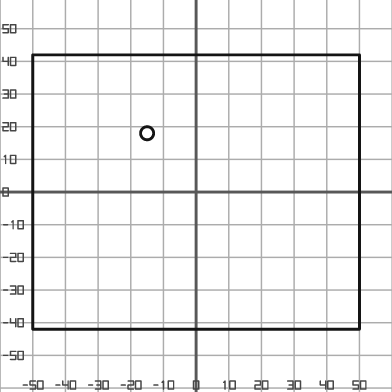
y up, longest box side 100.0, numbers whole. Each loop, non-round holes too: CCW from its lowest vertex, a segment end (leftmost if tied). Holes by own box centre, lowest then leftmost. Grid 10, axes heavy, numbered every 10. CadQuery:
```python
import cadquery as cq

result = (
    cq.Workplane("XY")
    .moveTo(-50.0, -42.0)
    .lineTo(50.0, -42.0)
    .lineTo(50.0, 42.0)
    .lineTo(-50.0, 42.0)
    .close()
    .moveTo(-15.0, 18.0)
    .circle(2.0)
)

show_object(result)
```